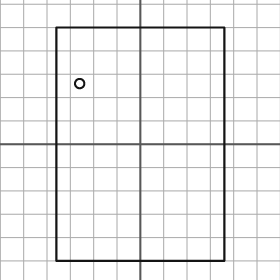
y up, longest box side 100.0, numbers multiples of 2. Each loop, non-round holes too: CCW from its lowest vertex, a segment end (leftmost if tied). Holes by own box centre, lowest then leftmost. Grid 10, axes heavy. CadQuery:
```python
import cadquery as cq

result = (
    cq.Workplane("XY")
    .moveTo(-36.0, -50.0)
    .lineTo(36.0, -50.0)
    .lineTo(36.0, 50.0)
    .lineTo(-36.0, 50.0)
    .close()
    .moveTo(-26.0, 26.0)
    .circle(2.0)
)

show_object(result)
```